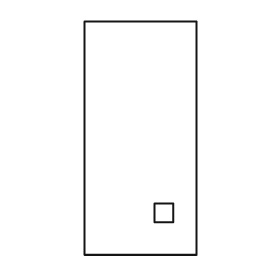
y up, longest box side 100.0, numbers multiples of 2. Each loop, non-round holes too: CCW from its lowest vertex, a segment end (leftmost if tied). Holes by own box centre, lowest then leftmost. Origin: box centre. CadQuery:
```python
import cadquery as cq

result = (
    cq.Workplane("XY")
    .moveTo(-24.0, -50.0)
    .lineTo(24.0, -50.0)
    .lineTo(24.0, 50.0)
    .lineTo(-24.0, 50.0)
    .close()
    .moveTo(6.0, -36.0)
    .lineTo(14.0, -36.0)
    .lineTo(14.0, -28.0)
    .lineTo(6.0, -28.0)
    .close()
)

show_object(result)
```